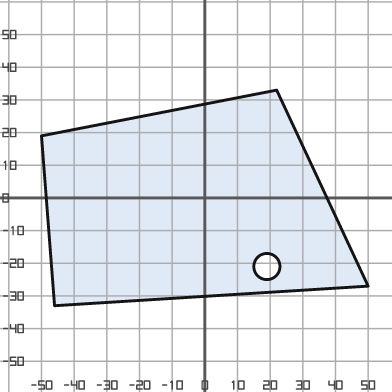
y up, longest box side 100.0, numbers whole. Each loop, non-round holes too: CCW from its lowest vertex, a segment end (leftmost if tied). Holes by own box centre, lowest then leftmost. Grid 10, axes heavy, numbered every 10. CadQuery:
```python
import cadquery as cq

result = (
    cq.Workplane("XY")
    .moveTo(-46.0, -33.0)
    .lineTo(50.0, -27.0)
    .lineTo(22.0, 33.0)
    .lineTo(-50.0, 19.0)
    .close()
    .moveTo(19.0, -21.0)
    .circle(4.0)
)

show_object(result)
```